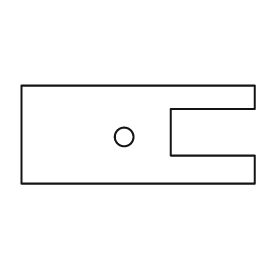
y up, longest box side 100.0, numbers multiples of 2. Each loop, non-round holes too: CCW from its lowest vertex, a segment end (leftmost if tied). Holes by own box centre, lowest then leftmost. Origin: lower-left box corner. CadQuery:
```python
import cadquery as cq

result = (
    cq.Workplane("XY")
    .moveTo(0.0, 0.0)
    .lineTo(100.0, 0.0)
    .lineTo(100.0, 12.0)
    .lineTo(64.0, 12.0)
    .lineTo(64.0, 32.0)
    .lineTo(100.0, 32.0)
    .lineTo(100.0, 42.0)
    .lineTo(0.0, 42.0)
    .close()
    .moveTo(44.0, 20.0)
    .circle(4.0)
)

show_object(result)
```